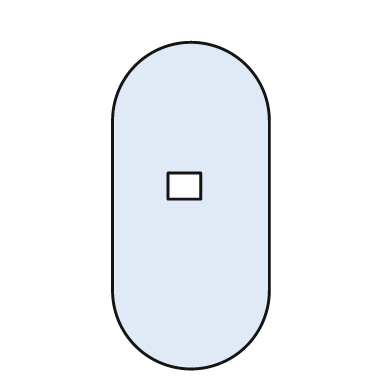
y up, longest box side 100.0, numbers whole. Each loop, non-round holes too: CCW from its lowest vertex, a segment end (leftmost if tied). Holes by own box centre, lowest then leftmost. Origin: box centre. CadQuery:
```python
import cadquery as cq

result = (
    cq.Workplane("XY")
    .moveTo(-24.0, -26.0)
    .threePointArc((0.0, -50.0), (24.0, -26.0))
    .lineTo(24.0, 26.0)
    .threePointArc((0.0, 50.0), (-24.0, 26.0))
    .close()
    .moveTo(-7.0, 2.0)
    .lineTo(3.0, 2.0)
    .lineTo(3.0, 10.0)
    .lineTo(-7.0, 10.0)
    .close()
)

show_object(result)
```